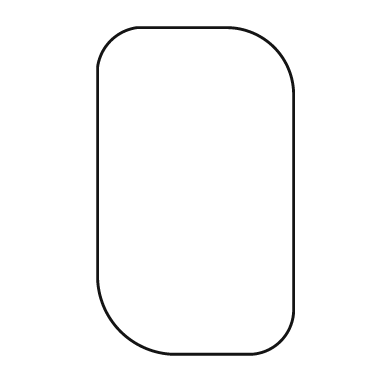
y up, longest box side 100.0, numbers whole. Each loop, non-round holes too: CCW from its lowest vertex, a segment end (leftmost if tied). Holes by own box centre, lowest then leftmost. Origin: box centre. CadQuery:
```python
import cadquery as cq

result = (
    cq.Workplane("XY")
    .moveTo(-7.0, -50.0)
    .lineTo(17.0, -50.0)
    .threePointArc((26.0, -46.0), (30.0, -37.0))
    .lineTo(30.0, 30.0)
    .threePointArc((24.0, 44.0), (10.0, 50.0))
    .lineTo(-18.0, 50.0)
    .threePointArc((-26.0, 46.0), (-30.0, 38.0))
    .lineTo(-30.0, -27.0)
    .threePointArc((-23.0, -43.0), (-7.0, -50.0))
    .close()
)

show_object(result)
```